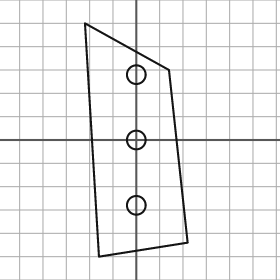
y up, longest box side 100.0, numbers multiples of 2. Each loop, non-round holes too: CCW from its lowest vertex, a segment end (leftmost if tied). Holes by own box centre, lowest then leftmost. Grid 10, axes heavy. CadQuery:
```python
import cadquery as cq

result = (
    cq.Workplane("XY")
    .moveTo(-16.0, -50.0)
    .lineTo(22.0, -44.0)
    .lineTo(14.0, 30.0)
    .lineTo(-22.0, 50.0)
    .close()
    .moveTo(0.0, -28.0)
    .circle(4.0)
    .moveTo(0.0, 0.0)
    .circle(4.0)
    .moveTo(0.0, 28.0)
    .circle(4.0)
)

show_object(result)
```